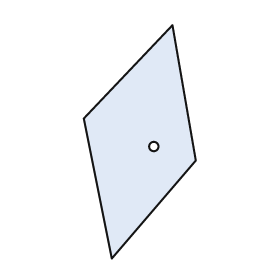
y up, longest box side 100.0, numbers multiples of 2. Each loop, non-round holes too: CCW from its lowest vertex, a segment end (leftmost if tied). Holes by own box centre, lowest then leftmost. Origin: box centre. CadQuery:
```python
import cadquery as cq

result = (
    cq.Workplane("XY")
    .moveTo(-12.0, -50.0)
    .lineTo(24.0, -8.0)
    .lineTo(14.0, 50.0)
    .lineTo(-24.0, 10.0)
    .close()
    .moveTo(6.0, -2.0)
    .circle(2.0)
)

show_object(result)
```